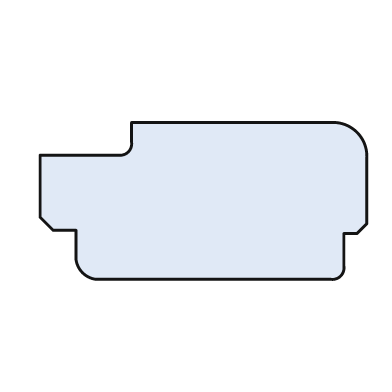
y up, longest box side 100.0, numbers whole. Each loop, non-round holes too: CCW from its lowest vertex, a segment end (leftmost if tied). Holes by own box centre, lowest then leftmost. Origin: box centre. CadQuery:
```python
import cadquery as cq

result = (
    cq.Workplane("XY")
    .moveTo(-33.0, -24.0)
    .lineTo(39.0, -24.0)
    .threePointArc((42.0, -23.0), (43.0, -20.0))
    .lineTo(43.0, -10.0)
    .lineTo(47.0, -10.0)
    .lineTo(50.0, -7.0)
    .lineTo(50.0, 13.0)
    .threePointArc((47.0, 21.0), (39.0, 24.0))
    .lineTo(-22.0, 24.0)
    .lineTo(-22.0, 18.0)
    .threePointArc((-23.0, 15.0), (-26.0, 14.0))
    .lineTo(-50.0, 14.0)
    .lineTo(-50.0, -5.0)
    .lineTo(-46.0, -9.0)
    .lineTo(-39.0, -9.0)
    .lineTo(-39.0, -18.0)
    .threePointArc((-37.0, -22.0), (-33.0, -24.0))
    .close()
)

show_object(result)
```